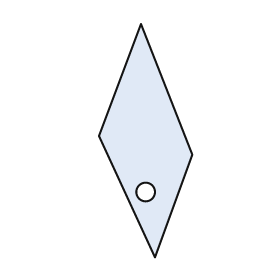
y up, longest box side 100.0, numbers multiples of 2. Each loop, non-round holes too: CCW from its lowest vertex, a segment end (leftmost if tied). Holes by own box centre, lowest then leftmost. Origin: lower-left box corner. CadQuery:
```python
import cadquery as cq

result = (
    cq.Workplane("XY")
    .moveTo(24.0, 0.0)
    .lineTo(40.0, 44.0)
    .lineTo(18.0, 100.0)
    .lineTo(0.0, 52.0)
    .close()
    .moveTo(20.0, 28.0)
    .circle(4.0)
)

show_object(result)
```